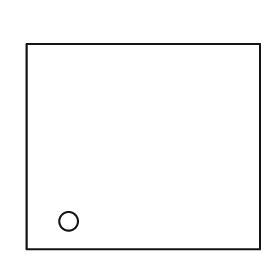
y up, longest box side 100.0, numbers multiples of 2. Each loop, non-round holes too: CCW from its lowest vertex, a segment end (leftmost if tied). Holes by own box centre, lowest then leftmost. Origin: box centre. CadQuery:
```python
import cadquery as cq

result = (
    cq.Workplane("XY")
    .moveTo(-50.0, -44.0)
    .lineTo(50.0, -44.0)
    .lineTo(50.0, 44.0)
    .lineTo(-50.0, 44.0)
    .close()
    .moveTo(-32.0, -32.0)
    .circle(4.0)
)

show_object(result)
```